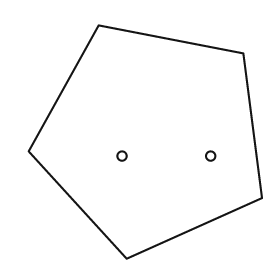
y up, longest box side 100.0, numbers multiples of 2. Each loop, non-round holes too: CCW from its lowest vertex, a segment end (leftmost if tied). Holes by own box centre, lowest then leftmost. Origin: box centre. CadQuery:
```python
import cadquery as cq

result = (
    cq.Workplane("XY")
    .moveTo(-8.0, -50.0)
    .lineTo(50.0, -24.0)
    .lineTo(42.0, 38.0)
    .lineTo(-20.0, 50.0)
    .lineTo(-50.0, -4.0)
    .close()
    .moveTo(-10.0, -6.0)
    .circle(2.0)
    .moveTo(28.0, -6.0)
    .circle(2.0)
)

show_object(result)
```